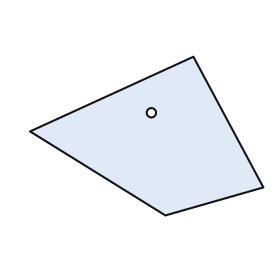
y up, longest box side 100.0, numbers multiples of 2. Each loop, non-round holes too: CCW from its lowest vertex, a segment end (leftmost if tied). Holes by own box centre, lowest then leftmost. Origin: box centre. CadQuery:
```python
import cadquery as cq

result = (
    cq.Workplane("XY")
    .moveTo(8.0, -34.0)
    .lineTo(50.0, -22.0)
    .lineTo(20.0, 34.0)
    .lineTo(-50.0, 2.0)
    .close()
    .moveTo(2.0, 10.0)
    .circle(2.0)
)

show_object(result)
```